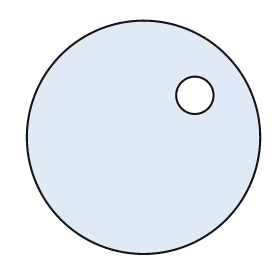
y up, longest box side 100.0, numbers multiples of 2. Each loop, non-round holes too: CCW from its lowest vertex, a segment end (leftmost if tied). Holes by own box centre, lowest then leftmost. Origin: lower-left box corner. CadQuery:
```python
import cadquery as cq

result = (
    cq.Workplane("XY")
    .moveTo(50.0, 50.0)
    .circle(50.0)
    .moveTo(72.0, 68.0)
    .circle(8.0)
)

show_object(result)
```